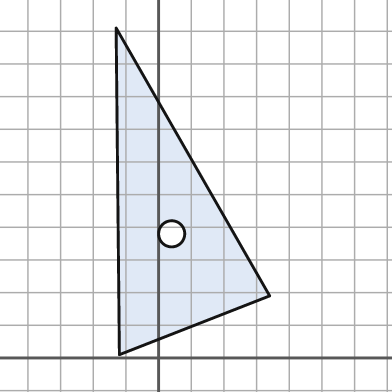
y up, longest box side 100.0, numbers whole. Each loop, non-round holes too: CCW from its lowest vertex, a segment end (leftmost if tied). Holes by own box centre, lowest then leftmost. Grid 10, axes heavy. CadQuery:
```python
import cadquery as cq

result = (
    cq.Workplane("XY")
    .moveTo(-12.0, 1.0)
    .lineTo(34.0, 19.0)
    .lineTo(-13.0, 101.0)
    .close()
    .moveTo(4.0, 38.0)
    .circle(4.0)
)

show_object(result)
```